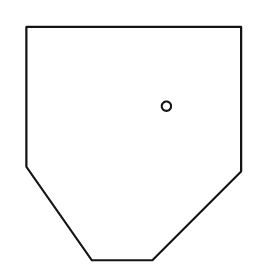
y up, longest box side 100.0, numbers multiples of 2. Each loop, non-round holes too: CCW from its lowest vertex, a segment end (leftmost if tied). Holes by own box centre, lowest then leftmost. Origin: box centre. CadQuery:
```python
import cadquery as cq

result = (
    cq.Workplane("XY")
    .moveTo(-18.0, -50.0)
    .lineTo(8.0, -50.0)
    .lineTo(46.0, -12.0)
    .lineTo(46.0, 50.0)
    .lineTo(-46.0, 50.0)
    .lineTo(-46.0, -10.0)
    .close()
    .moveTo(14.0, 16.0)
    .circle(2.0)
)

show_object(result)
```